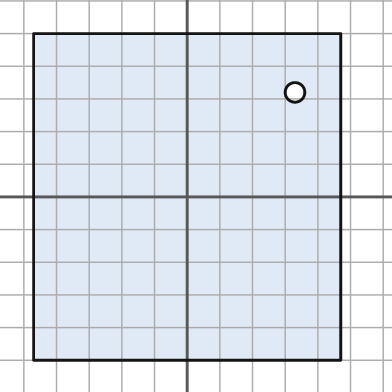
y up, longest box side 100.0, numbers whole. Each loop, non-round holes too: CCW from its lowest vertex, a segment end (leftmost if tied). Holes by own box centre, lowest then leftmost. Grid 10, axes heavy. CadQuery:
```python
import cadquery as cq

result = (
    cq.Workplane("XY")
    .moveTo(-47.0, -50.0)
    .lineTo(47.0, -50.0)
    .lineTo(47.0, 50.0)
    .lineTo(-47.0, 50.0)
    .close()
    .moveTo(33.0, 32.0)
    .circle(3.0)
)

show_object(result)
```